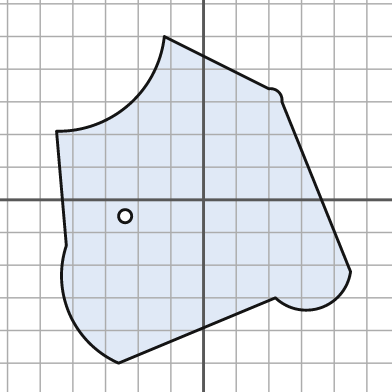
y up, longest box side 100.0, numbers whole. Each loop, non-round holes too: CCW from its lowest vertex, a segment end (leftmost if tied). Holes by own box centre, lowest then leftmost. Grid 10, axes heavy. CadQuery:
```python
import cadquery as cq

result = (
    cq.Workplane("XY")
    .moveTo(-26.0, -50.0)
    .lineTo(22.0, -30.0)
    .threePointArc((36.0, -33.0), (45.0, -22.0))
    .lineTo(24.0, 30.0)
    .threePointArc((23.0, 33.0), (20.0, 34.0))
    .lineTo(-12.0, 50.0)
    .threePointArc((-23.0, 29.0), (-45.0, 21.0))
    .lineTo(-42.0, -14.0)
    .threePointArc((-41.0, -35.0), (-26.0, -50.0))
    .close()
    .moveTo(-24.0, -5.0)
    .circle(2.0)
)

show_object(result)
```